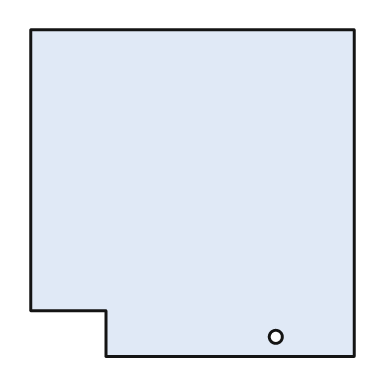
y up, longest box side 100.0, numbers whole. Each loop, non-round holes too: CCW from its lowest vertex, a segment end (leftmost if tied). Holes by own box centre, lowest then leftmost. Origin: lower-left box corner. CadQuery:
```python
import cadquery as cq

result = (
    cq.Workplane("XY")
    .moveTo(23.0, 0.0)
    .lineTo(99.0, 0.0)
    .lineTo(99.0, 100.0)
    .lineTo(0.0, 100.0)
    .lineTo(0.0, 14.0)
    .lineTo(23.0, 14.0)
    .close()
    .moveTo(75.0, 6.0)
    .circle(2.0)
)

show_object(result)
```